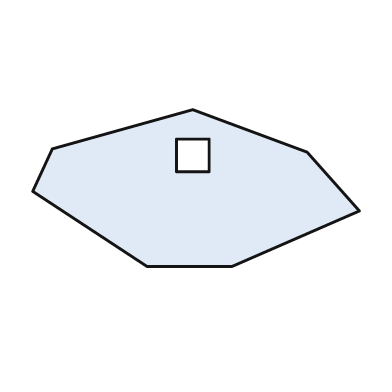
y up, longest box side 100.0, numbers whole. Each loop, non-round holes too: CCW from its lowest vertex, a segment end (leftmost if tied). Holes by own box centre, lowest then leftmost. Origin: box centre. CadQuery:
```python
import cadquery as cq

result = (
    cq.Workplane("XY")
    .moveTo(-15.0, -24.0)
    .lineTo(11.0, -24.0)
    .lineTo(50.0, -7.0)
    .lineTo(34.0, 11.0)
    .lineTo(-1.0, 24.0)
    .lineTo(-44.0, 12.0)
    .lineTo(-50.0, -1.0)
    .close()
    .moveTo(-6.0, 5.0)
    .lineTo(4.0, 5.0)
    .lineTo(4.0, 15.0)
    .lineTo(-6.0, 15.0)
    .close()
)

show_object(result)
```